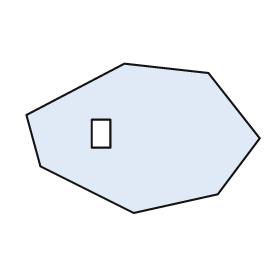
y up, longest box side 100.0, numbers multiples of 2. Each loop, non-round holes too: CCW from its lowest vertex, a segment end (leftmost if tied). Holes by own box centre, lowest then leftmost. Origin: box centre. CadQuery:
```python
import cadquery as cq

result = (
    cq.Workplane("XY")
    .moveTo(-4.0, -32.0)
    .lineTo(32.0, -24.0)
    .lineTo(50.0, 0.0)
    .lineTo(28.0, 28.0)
    .lineTo(-8.0, 32.0)
    .lineTo(-50.0, 10.0)
    .lineTo(-44.0, -12.0)
    .close()
    .moveTo(-22.0, -4.0)
    .lineTo(-14.0, -4.0)
    .lineTo(-14.0, 8.0)
    .lineTo(-22.0, 8.0)
    .close()
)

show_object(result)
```